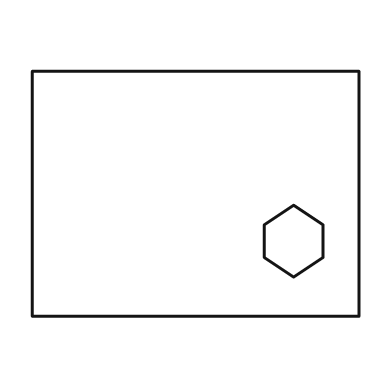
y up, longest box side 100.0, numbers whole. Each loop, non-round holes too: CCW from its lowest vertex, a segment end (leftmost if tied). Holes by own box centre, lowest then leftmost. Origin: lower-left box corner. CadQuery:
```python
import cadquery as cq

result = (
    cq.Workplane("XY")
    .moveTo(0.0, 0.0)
    .lineTo(100.0, 0.0)
    .lineTo(100.0, 75.0)
    .lineTo(0.0, 75.0)
    .close()
    .moveTo(80.0, 12.0)
    .lineTo(89.0, 18.0)
    .lineTo(89.0, 28.0)
    .lineTo(80.0, 34.0)
    .lineTo(71.0, 28.0)
    .lineTo(71.0, 18.0)
    .close()
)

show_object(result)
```